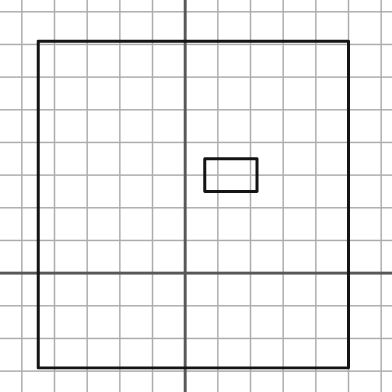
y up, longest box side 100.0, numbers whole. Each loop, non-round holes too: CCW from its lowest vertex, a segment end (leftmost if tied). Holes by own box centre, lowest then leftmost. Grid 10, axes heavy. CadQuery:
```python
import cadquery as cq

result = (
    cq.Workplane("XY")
    .moveTo(-45.0, -29.0)
    .lineTo(50.0, -29.0)
    .lineTo(50.0, 71.0)
    .lineTo(-45.0, 71.0)
    .close()
    .moveTo(6.0, 25.0)
    .lineTo(22.0, 25.0)
    .lineTo(22.0, 35.0)
    .lineTo(6.0, 35.0)
    .close()
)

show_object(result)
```